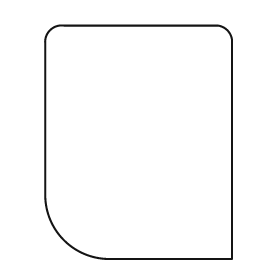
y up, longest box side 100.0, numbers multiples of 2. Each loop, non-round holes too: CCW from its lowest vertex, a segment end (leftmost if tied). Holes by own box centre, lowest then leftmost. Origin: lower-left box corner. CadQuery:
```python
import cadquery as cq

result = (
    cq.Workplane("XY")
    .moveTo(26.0, 0.0)
    .lineTo(80.0, 0.0)
    .lineTo(80.0, 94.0)
    .threePointArc((78.0, 98.0), (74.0, 100.0))
    .lineTo(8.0, 100.0)
    .threePointArc((2.0, 98.0), (0.0, 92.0))
    .lineTo(0.0, 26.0)
    .threePointArc((8.0, 8.0), (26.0, 0.0))
    .close()
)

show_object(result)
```